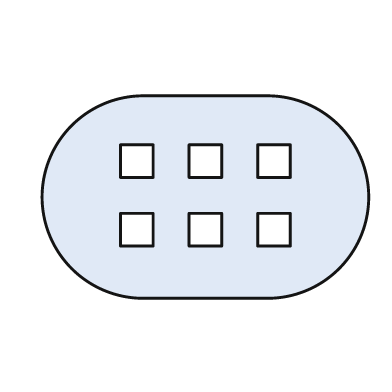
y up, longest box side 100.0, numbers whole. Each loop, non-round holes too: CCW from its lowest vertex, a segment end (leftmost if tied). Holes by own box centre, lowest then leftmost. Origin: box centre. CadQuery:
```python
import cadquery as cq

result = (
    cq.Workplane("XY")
    .moveTo(-19.0, -31.0)
    .lineTo(19.0, -31.0)
    .threePointArc((50.0, 0.0), (19.0, 31.0))
    .lineTo(-19.0, 31.0)
    .threePointArc((-50.0, 0.0), (-19.0, -31.0))
    .close()
    .moveTo(-26.0, -15.0)
    .lineTo(-16.0, -15.0)
    .lineTo(-16.0, -5.0)
    .lineTo(-26.0, -5.0)
    .close()
    .moveTo(-5.0, -15.0)
    .lineTo(5.0, -15.0)
    .lineTo(5.0, -5.0)
    .lineTo(-5.0, -5.0)
    .close()
    .moveTo(16.0, -15.0)
    .lineTo(26.0, -15.0)
    .lineTo(26.0, -5.0)
    .lineTo(16.0, -5.0)
    .close()
    .moveTo(-26.0, 6.0)
    .lineTo(-16.0, 6.0)
    .lineTo(-16.0, 16.0)
    .lineTo(-26.0, 16.0)
    .close()
    .moveTo(-5.0, 6.0)
    .lineTo(5.0, 6.0)
    .lineTo(5.0, 16.0)
    .lineTo(-5.0, 16.0)
    .close()
    .moveTo(16.0, 6.0)
    .lineTo(26.0, 6.0)
    .lineTo(26.0, 16.0)
    .lineTo(16.0, 16.0)
    .close()
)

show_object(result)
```